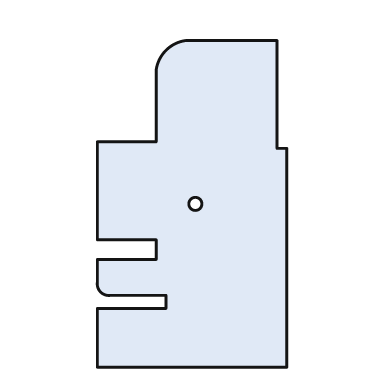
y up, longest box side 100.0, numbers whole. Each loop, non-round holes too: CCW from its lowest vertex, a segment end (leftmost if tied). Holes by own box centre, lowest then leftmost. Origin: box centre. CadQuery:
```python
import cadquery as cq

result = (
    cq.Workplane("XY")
    .moveTo(-29.0, -50.0)
    .lineTo(29.0, -50.0)
    .lineTo(29.0, 17.0)
    .lineTo(26.0, 17.0)
    .lineTo(26.0, 50.0)
    .lineTo(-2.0, 50.0)
    .threePointArc((-8.0, 47.0), (-11.0, 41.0))
    .lineTo(-11.0, 19.0)
    .lineTo(-29.0, 19.0)
    .lineTo(-29.0, -11.0)
    .lineTo(-11.0, -11.0)
    .lineTo(-11.0, -17.0)
    .lineTo(-29.0, -17.0)
    .lineTo(-29.0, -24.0)
    .threePointArc((-28.0, -27.0), (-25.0, -28.0))
    .lineTo(-8.0, -28.0)
    .lineTo(-8.0, -32.0)
    .lineTo(-29.0, -32.0)
    .close()
    .moveTo(1.0, 0.0)
    .circle(2.0)
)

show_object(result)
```